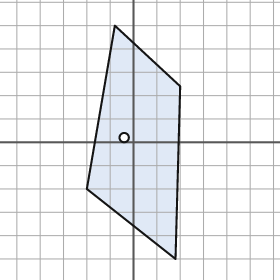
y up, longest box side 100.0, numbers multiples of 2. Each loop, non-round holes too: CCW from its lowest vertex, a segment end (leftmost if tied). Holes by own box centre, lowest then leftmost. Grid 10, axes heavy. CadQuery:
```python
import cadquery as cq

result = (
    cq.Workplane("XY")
    .moveTo(18.0, -50.0)
    .lineTo(20.0, 24.0)
    .lineTo(-8.0, 50.0)
    .lineTo(-20.0, -20.0)
    .close()
    .moveTo(-4.0, 2.0)
    .circle(2.0)
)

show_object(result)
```